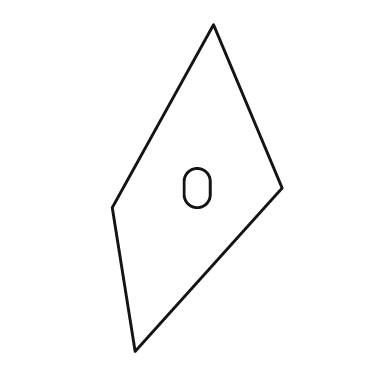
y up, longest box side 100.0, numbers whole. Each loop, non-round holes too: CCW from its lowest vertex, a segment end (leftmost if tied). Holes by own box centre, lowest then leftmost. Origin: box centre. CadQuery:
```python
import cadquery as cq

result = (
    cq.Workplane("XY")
    .moveTo(-19.0, -50.0)
    .lineTo(26.0, 0.0)
    .lineTo(5.0, 50.0)
    .lineTo(-26.0, -6.0)
    .close()
    .moveTo(-4.0, -2.0)
    .threePointArc((0.0, -6.0), (4.0, -2.0))
    .lineTo(4.0, 2.0)
    .threePointArc((0.0, 6.0), (-4.0, 2.0))
    .close()
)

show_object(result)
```